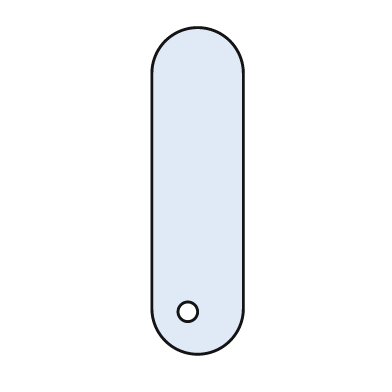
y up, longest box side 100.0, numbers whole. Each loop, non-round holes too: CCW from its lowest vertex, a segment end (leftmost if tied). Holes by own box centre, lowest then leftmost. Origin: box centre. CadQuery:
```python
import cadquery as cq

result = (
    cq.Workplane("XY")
    .moveTo(-14.0, -36.0)
    .threePointArc((0.0, -50.0), (14.0, -36.0))
    .lineTo(14.0, 36.0)
    .threePointArc((0.0, 50.0), (-14.0, 36.0))
    .close()
    .moveTo(-3.0, -37.0)
    .circle(3.0)
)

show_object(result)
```